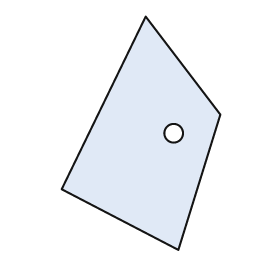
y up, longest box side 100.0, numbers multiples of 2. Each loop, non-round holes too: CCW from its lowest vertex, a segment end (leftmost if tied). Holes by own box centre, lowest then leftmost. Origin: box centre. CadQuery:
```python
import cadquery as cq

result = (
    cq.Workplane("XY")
    .moveTo(16.0, -50.0)
    .lineTo(34.0, 8.0)
    .lineTo(2.0, 50.0)
    .lineTo(-34.0, -24.0)
    .close()
    .moveTo(14.0, 0.0)
    .circle(4.0)
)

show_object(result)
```